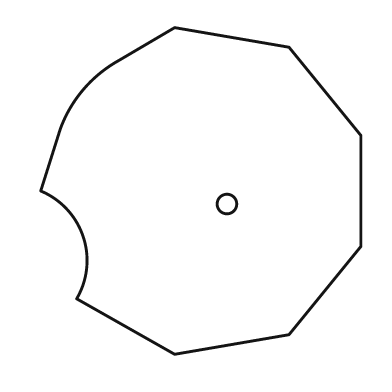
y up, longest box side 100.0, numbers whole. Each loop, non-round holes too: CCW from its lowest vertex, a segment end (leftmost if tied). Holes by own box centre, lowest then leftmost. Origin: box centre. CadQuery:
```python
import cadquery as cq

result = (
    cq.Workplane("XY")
    .moveTo(-8.0, -50.0)
    .lineTo(27.0, -44.0)
    .lineTo(49.0, -17.0)
    .lineTo(49.0, 17.0)
    .lineTo(27.0, 44.0)
    .lineTo(-8.0, 50.0)
    .lineTo(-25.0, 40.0)
    .threePointArc((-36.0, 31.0), (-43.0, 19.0))
    .lineTo(-49.0, 0.0)
    .threePointArc((-36.0, -14.0), (-38.0, -33.0))
    .close()
    .moveTo(8.0, -4.0)
    .circle(3.0)
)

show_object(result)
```